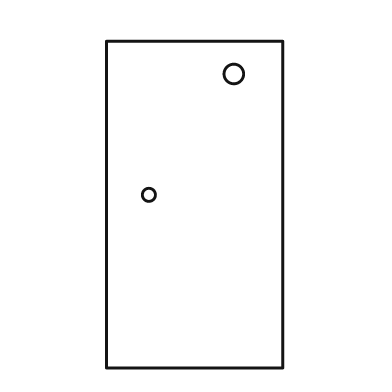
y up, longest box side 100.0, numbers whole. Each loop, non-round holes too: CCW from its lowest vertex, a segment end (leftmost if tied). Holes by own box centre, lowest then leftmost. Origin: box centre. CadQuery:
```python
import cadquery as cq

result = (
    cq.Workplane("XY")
    .moveTo(-27.0, -50.0)
    .lineTo(27.0, -50.0)
    .lineTo(27.0, 50.0)
    .lineTo(-27.0, 50.0)
    .close()
    .moveTo(-14.0, 3.0)
    .circle(2.0)
    .moveTo(12.0, 40.0)
    .circle(3.0)
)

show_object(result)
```